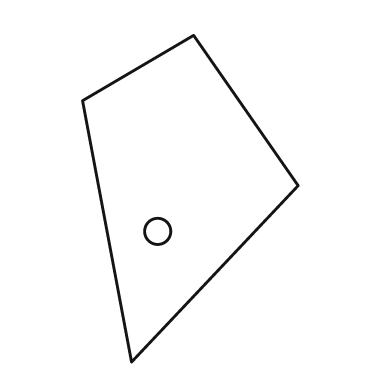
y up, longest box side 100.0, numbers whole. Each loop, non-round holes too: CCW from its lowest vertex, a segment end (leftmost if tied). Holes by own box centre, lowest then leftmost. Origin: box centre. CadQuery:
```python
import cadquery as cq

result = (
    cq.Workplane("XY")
    .moveTo(-18.0, -50.0)
    .lineTo(33.0, 4.0)
    .lineTo(1.0, 50.0)
    .lineTo(-33.0, 30.0)
    .close()
    .moveTo(-10.0, -10.0)
    .circle(4.0)
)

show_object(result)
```